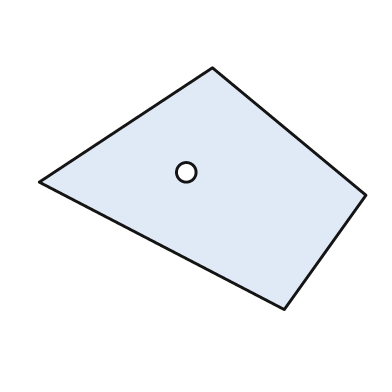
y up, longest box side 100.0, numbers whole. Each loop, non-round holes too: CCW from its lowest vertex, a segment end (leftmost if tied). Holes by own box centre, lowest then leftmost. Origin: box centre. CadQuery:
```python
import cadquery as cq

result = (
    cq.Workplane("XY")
    .moveTo(25.0, -37.0)
    .lineTo(50.0, -2.0)
    .lineTo(3.0, 37.0)
    .lineTo(-50.0, 2.0)
    .close()
    .moveTo(-5.0, 5.0)
    .circle(3.0)
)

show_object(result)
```